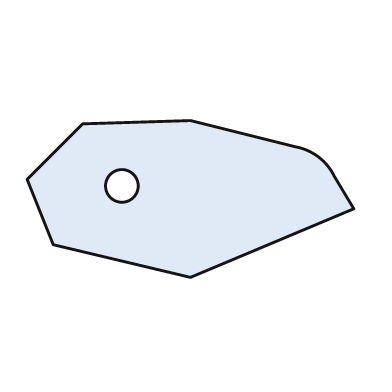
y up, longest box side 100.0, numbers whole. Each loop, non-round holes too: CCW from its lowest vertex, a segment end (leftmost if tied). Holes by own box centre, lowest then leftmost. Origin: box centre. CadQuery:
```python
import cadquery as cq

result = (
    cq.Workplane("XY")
    .moveTo(0.0, -24.0)
    .lineTo(50.0, -3.0)
    .lineTo(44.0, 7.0)
    .threePointArc((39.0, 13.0), (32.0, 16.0))
    .lineTo(0.0, 24.0)
    .lineTo(-33.0, 23.0)
    .lineTo(-50.0, 6.0)
    .lineTo(-42.0, -14.0)
    .close()
    .moveTo(-21.0, 4.0)
    .circle(5.0)
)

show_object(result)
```